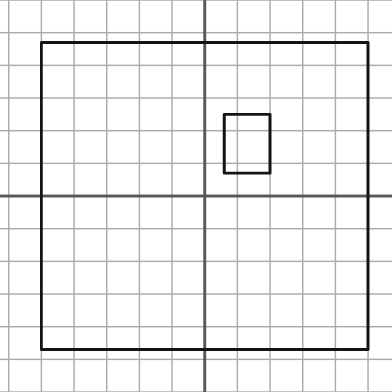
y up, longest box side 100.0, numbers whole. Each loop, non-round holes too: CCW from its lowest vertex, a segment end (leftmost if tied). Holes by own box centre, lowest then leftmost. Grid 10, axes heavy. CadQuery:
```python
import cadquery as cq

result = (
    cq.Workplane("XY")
    .moveTo(-50.0, -47.0)
    .lineTo(50.0, -47.0)
    .lineTo(50.0, 47.0)
    .lineTo(-50.0, 47.0)
    .close()
    .moveTo(6.0, 7.0)
    .lineTo(20.0, 7.0)
    .lineTo(20.0, 25.0)
    .lineTo(6.0, 25.0)
    .close()
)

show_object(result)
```